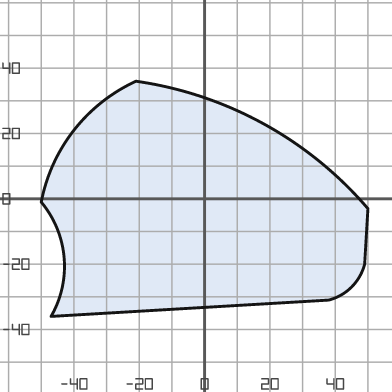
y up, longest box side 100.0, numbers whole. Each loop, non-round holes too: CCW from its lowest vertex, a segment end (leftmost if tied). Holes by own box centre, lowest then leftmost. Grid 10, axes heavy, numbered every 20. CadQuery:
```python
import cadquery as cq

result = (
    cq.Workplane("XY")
    .moveTo(-47.0, -36.0)
    .lineTo(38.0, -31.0)
    .threePointArc((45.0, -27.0), (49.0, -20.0))
    .lineTo(50.0, -3.0)
    .threePointArc((18.0, 23.0), (-21.0, 36.0))
    .threePointArc((-40.0, 21.0), (-50.0, -1.0))
    .threePointArc((-43.0, -18.0), (-47.0, -36.0))
    .close()
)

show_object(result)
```